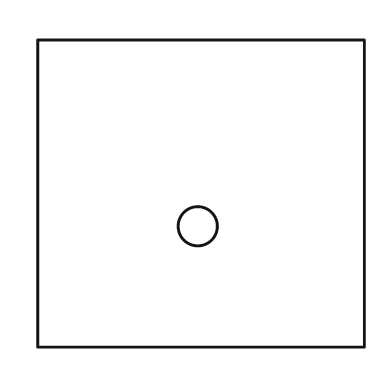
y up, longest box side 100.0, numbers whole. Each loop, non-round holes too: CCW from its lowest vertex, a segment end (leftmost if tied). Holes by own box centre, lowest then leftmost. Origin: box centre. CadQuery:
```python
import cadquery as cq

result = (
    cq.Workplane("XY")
    .moveTo(-50.0, -47.0)
    .lineTo(50.0, -47.0)
    .lineTo(50.0, 47.0)
    .lineTo(-50.0, 47.0)
    .close()
    .moveTo(-1.0, -10.0)
    .circle(6.0)
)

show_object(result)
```